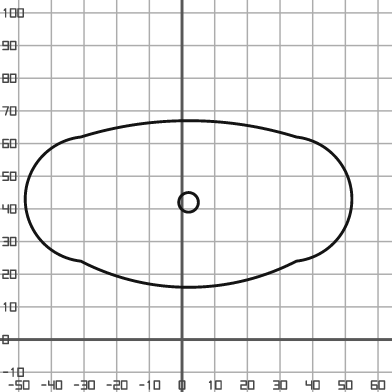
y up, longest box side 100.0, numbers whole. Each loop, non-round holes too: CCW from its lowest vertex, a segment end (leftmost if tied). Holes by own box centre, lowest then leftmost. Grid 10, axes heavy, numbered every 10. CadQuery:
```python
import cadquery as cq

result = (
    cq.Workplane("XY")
    .moveTo(-31.0, 24.0)
    .threePointArc((2.0, 16.0), (35.0, 24.0))
    .threePointArc((52.0, 43.0), (35.0, 62.0))
    .threePointArc((2.0, 67.0), (-31.0, 62.0))
    .threePointArc((-48.0, 43.0), (-31.0, 24.0))
    .close()
    .moveTo(2.0, 42.0)
    .circle(3.0)
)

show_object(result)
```